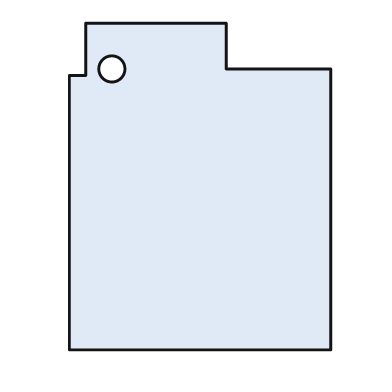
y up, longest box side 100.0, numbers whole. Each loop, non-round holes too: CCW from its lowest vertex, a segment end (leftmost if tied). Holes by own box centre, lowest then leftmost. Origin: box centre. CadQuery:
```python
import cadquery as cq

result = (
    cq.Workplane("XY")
    .moveTo(-40.0, -50.0)
    .lineTo(40.0, -50.0)
    .lineTo(40.0, 36.0)
    .lineTo(8.0, 36.0)
    .lineTo(8.0, 50.0)
    .lineTo(-35.0, 50.0)
    .lineTo(-35.0, 34.0)
    .lineTo(-40.0, 34.0)
    .close()
    .moveTo(-27.0, 36.0)
    .circle(4.0)
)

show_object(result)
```